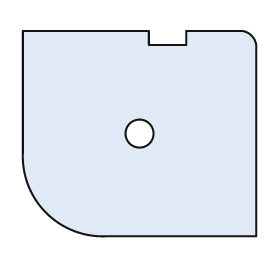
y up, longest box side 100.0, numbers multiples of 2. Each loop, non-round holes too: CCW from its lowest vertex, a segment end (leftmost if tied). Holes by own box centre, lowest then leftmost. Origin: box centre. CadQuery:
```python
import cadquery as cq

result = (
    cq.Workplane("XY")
    .moveTo(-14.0, -44.0)
    .lineTo(50.0, -44.0)
    .lineTo(50.0, 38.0)
    .threePointArc((48.0, 42.0), (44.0, 44.0))
    .lineTo(20.0, 44.0)
    .lineTo(20.0, 38.0)
    .lineTo(4.0, 38.0)
    .lineTo(4.0, 44.0)
    .lineTo(-50.0, 44.0)
    .lineTo(-50.0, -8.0)
    .threePointArc((-40.0, -34.0), (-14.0, -44.0))
    .close()
    .moveTo(0.0, 0.0)
    .circle(6.0)
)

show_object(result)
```